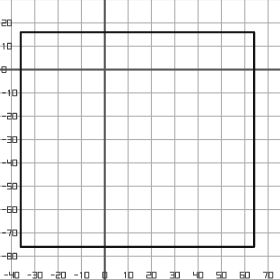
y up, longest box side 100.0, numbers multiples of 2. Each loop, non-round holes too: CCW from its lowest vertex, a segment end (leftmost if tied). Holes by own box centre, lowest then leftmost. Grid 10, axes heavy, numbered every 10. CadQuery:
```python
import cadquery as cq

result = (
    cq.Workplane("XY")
    .moveTo(-36.0, -76.0)
    .lineTo(64.0, -76.0)
    .lineTo(64.0, 16.0)
    .lineTo(-36.0, 16.0)
    .close()
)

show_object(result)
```